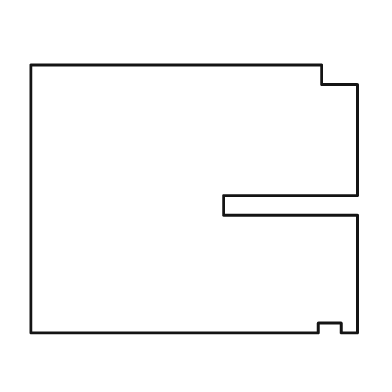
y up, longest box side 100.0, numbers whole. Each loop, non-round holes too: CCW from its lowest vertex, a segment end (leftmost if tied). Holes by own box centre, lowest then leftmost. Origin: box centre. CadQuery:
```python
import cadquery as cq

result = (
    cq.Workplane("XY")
    .moveTo(-50.0, -41.0)
    .lineTo(38.0, -41.0)
    .lineTo(38.0, -38.0)
    .lineTo(45.0, -38.0)
    .lineTo(45.0, -41.0)
    .lineTo(50.0, -41.0)
    .lineTo(50.0, -5.0)
    .lineTo(9.0, -5.0)
    .lineTo(9.0, 1.0)
    .lineTo(50.0, 1.0)
    .lineTo(50.0, 35.0)
    .lineTo(39.0, 35.0)
    .lineTo(39.0, 41.0)
    .lineTo(-50.0, 41.0)
    .close()
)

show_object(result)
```